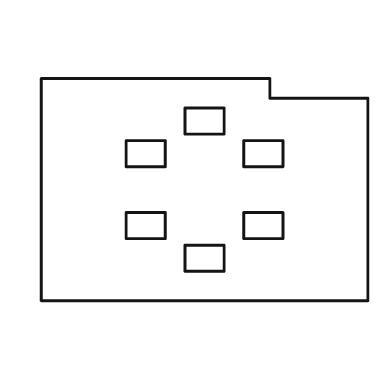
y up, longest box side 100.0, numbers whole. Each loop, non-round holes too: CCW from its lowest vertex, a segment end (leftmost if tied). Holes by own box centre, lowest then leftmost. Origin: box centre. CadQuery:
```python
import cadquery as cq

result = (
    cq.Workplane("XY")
    .moveTo(-50.0, -34.0)
    .lineTo(50.0, -34.0)
    .lineTo(50.0, 28.0)
    .lineTo(20.0, 28.0)
    .lineTo(20.0, 34.0)
    .lineTo(-50.0, 34.0)
    .close()
    .moveTo(-6.0, -25.0)
    .lineTo(6.0, -25.0)
    .lineTo(6.0, -17.0)
    .lineTo(-6.0, -17.0)
    .close()
    .moveTo(-24.0, -15.0)
    .lineTo(-12.0, -15.0)
    .lineTo(-12.0, -7.0)
    .lineTo(-24.0, -7.0)
    .close()
    .moveTo(12.0, -15.0)
    .lineTo(24.0, -15.0)
    .lineTo(24.0, -7.0)
    .lineTo(12.0, -7.0)
    .close()
    .moveTo(-24.0, 7.0)
    .lineTo(-12.0, 7.0)
    .lineTo(-12.0, 15.0)
    .lineTo(-24.0, 15.0)
    .close()
    .moveTo(12.0, 7.0)
    .lineTo(24.0, 7.0)
    .lineTo(24.0, 15.0)
    .lineTo(12.0, 15.0)
    .close()
    .moveTo(-6.0, 17.0)
    .lineTo(6.0, 17.0)
    .lineTo(6.0, 25.0)
    .lineTo(-6.0, 25.0)
    .close()
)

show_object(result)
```